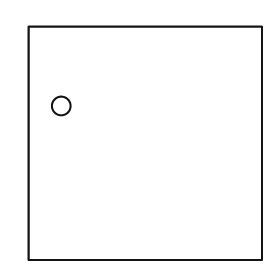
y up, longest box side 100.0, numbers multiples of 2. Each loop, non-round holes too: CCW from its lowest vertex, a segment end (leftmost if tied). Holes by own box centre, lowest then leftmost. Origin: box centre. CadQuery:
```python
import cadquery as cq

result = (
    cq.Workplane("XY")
    .moveTo(-50.0, -50.0)
    .lineTo(50.0, -50.0)
    .lineTo(50.0, 50.0)
    .lineTo(-50.0, 50.0)
    .close()
    .moveTo(-36.0, 16.0)
    .circle(4.0)
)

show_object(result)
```